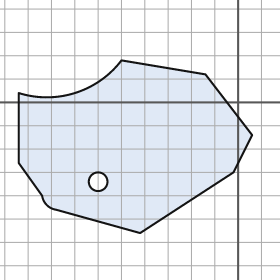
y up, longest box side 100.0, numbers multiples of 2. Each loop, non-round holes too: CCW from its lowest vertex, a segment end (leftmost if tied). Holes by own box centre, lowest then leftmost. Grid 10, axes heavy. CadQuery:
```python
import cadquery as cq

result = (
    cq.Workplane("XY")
    .moveTo(-42.0, -56.0)
    .lineTo(-2.0, -30.0)
    .lineTo(6.0, -14.0)
    .lineTo(-14.0, 12.0)
    .lineTo(-50.0, 18.0)
    .threePointArc((-70.0, 4.0), (-94.0, 4.0))
    .lineTo(-94.0, -26.0)
    .lineTo(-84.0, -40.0)
    .threePointArc((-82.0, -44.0), (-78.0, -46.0))
    .close()
    .moveTo(-60.0, -34.0)
    .circle(4.0)
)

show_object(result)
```